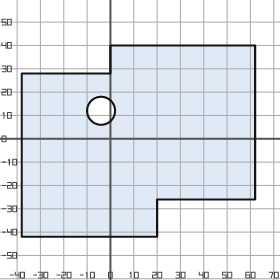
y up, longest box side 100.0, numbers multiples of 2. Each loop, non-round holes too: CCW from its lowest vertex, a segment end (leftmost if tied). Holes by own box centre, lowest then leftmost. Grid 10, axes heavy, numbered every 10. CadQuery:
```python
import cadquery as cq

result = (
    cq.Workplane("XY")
    .moveTo(-38.0, -42.0)
    .lineTo(20.0, -42.0)
    .lineTo(20.0, -26.0)
    .lineTo(62.0, -26.0)
    .lineTo(62.0, 40.0)
    .lineTo(0.0, 40.0)
    .lineTo(0.0, 28.0)
    .lineTo(-38.0, 28.0)
    .close()
    .moveTo(-4.0, 12.0)
    .circle(6.0)
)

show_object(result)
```